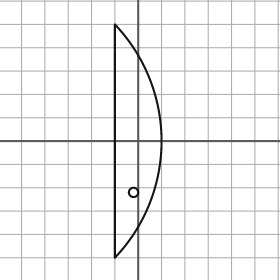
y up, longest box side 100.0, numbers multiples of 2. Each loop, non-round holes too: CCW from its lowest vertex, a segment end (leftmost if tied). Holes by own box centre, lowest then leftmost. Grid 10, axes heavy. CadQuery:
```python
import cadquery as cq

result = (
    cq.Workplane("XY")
    .moveTo(-10.0, -50.0)
    .threePointArc((10.0, 0.0), (-10.0, 50.0))
    .close()
    .moveTo(-2.0, -22.0)
    .circle(2.0)
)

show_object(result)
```